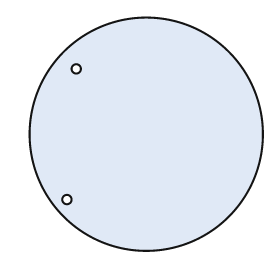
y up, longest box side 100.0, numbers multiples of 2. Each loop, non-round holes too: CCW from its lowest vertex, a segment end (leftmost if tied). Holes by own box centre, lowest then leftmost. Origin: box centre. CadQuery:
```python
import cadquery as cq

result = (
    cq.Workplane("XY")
    .moveTo(0.0, 0.0)
    .circle(50.0)
    .moveTo(-34.0, -28.0)
    .circle(2.0)
    .moveTo(-30.0, 28.0)
    .circle(2.0)
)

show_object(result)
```